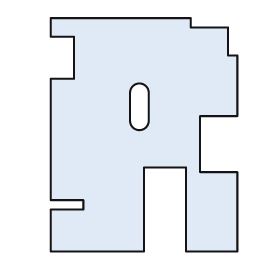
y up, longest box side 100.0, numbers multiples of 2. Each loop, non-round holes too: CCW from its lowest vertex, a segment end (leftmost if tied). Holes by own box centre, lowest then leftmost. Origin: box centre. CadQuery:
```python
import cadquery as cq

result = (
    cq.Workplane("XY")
    .moveTo(-40.0, -50.0)
    .lineTo(0.0, -50.0)
    .lineTo(0.0, -14.0)
    .lineTo(18.0, -14.0)
    .lineTo(18.0, -50.0)
    .lineTo(40.0, -50.0)
    .lineTo(40.0, -16.0)
    .lineTo(24.0, -16.0)
    .lineTo(24.0, 8.0)
    .lineTo(40.0, 8.0)
    .lineTo(40.0, 34.0)
    .lineTo(36.0, 34.0)
    .lineTo(36.0, 46.0)
    .lineTo(20.0, 46.0)
    .lineTo(20.0, 50.0)
    .lineTo(-40.0, 50.0)
    .lineTo(-40.0, 42.0)
    .lineTo(-30.0, 42.0)
    .lineTo(-30.0, 24.0)
    .lineTo(-40.0, 24.0)
    .lineTo(-40.0, -28.0)
    .lineTo(-26.0, -28.0)
    .lineTo(-26.0, -32.0)
    .lineTo(-40.0, -32.0)
    .close()
    .moveTo(-6.0, 6.0)
    .threePointArc((-2.0, 2.0), (2.0, 6.0))
    .lineTo(2.0, 18.0)
    .threePointArc((-2.0, 22.0), (-6.0, 18.0))
    .close()
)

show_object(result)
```